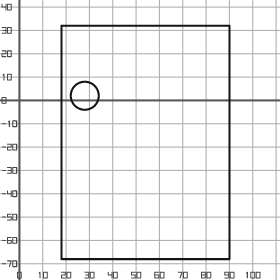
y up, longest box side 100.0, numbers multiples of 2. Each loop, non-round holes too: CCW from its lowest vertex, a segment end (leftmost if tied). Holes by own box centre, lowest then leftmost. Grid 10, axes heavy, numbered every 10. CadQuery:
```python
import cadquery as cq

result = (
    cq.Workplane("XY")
    .moveTo(18.0, -68.0)
    .lineTo(90.0, -68.0)
    .lineTo(90.0, 32.0)
    .lineTo(18.0, 32.0)
    .close()
    .moveTo(28.0, 2.0)
    .circle(6.0)
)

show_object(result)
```